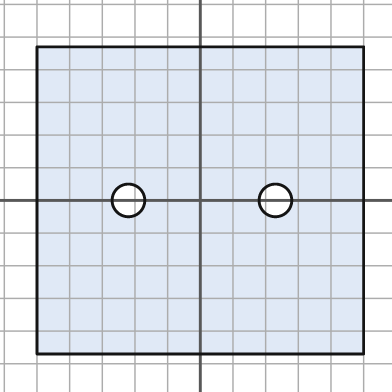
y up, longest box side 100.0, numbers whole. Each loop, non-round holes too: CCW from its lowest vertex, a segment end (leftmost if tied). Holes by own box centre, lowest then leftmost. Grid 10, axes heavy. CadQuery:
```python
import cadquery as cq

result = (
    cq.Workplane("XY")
    .moveTo(-50.0, -47.0)
    .lineTo(50.0, -47.0)
    .lineTo(50.0, 47.0)
    .lineTo(-50.0, 47.0)
    .close()
    .moveTo(-22.0, 0.0)
    .circle(5.0)
    .moveTo(23.0, 0.0)
    .circle(5.0)
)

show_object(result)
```